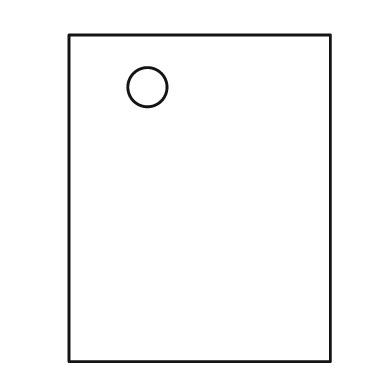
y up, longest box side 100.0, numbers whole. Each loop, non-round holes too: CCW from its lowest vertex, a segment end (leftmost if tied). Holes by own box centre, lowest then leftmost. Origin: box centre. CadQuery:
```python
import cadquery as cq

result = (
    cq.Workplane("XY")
    .moveTo(-40.0, -50.0)
    .lineTo(40.0, -50.0)
    .lineTo(40.0, 50.0)
    .lineTo(-40.0, 50.0)
    .close()
    .moveTo(-16.0, 34.0)
    .circle(6.0)
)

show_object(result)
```